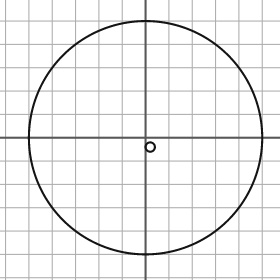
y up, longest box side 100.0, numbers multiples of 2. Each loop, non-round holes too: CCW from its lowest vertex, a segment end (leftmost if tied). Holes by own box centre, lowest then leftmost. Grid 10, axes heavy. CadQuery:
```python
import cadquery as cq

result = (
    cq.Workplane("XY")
    .moveTo(0.0, 0.0)
    .circle(50.0)
    .moveTo(2.0, -4.0)
    .circle(2.0)
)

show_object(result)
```